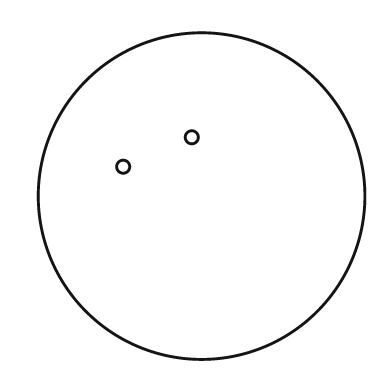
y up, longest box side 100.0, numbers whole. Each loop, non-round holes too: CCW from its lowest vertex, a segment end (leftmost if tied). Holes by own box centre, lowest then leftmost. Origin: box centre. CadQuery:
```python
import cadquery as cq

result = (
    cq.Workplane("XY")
    .moveTo(0.0, 0.0)
    .circle(50.0)
    .moveTo(-24.0, 9.0)
    .circle(2.0)
    .moveTo(-3.0, 18.0)
    .circle(2.0)
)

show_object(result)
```